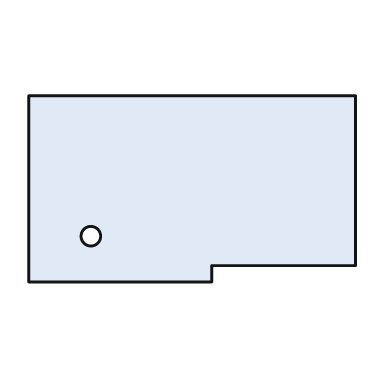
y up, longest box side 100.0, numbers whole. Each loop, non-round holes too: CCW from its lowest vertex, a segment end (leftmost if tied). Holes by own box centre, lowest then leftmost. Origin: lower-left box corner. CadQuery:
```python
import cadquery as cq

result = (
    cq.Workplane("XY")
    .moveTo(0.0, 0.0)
    .lineTo(56.0, 0.0)
    .lineTo(56.0, 5.0)
    .lineTo(100.0, 5.0)
    .lineTo(100.0, 57.0)
    .lineTo(0.0, 57.0)
    .close()
    .moveTo(19.0, 14.0)
    .circle(3.0)
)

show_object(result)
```